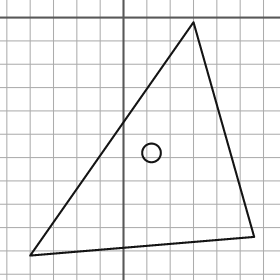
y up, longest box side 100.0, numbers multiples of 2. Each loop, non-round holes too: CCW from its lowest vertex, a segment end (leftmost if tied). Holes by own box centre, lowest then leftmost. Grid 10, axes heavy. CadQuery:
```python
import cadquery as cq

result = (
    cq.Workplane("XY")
    .moveTo(-40.0, -102.0)
    .lineTo(56.0, -94.0)
    .lineTo(30.0, -2.0)
    .close()
    .moveTo(12.0, -58.0)
    .circle(4.0)
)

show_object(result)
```